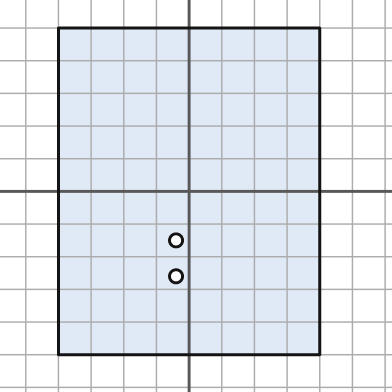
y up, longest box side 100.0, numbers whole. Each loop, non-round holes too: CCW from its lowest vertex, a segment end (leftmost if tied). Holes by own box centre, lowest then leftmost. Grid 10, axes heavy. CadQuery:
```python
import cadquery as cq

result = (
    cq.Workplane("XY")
    .moveTo(-40.0, -50.0)
    .lineTo(40.0, -50.0)
    .lineTo(40.0, 50.0)
    .lineTo(-40.0, 50.0)
    .close()
    .moveTo(-4.0, -26.0)
    .circle(2.0)
    .moveTo(-4.0, -15.0)
    .circle(2.0)
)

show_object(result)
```